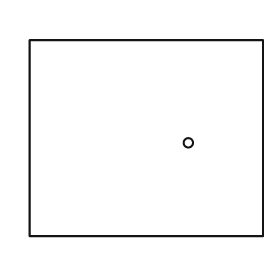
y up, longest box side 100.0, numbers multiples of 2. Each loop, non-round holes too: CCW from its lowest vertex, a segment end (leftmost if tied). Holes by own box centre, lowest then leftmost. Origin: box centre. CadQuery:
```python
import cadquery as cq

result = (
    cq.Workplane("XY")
    .moveTo(-50.0, -42.0)
    .lineTo(50.0, -42.0)
    .lineTo(50.0, 42.0)
    .lineTo(-50.0, 42.0)
    .close()
    .moveTo(18.0, -2.0)
    .circle(2.0)
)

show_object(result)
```